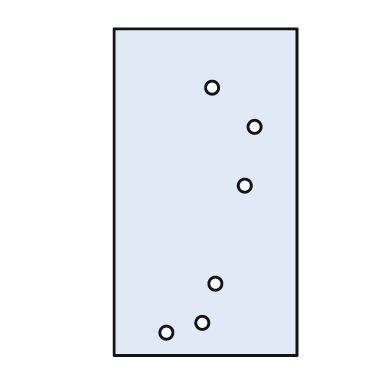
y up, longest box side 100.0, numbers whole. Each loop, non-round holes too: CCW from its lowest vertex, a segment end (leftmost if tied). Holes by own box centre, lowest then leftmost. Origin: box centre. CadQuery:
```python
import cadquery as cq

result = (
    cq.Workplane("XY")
    .moveTo(-28.0, -50.0)
    .lineTo(28.0, -50.0)
    .lineTo(28.0, 50.0)
    .lineTo(-28.0, 50.0)
    .close()
    .moveTo(-12.0, -43.0)
    .circle(2.0)
    .moveTo(-1.0, -40.0)
    .circle(2.0)
    .moveTo(3.0, -28.0)
    .circle(2.0)
    .moveTo(12.0, 2.0)
    .circle(2.0)
    .moveTo(15.0, 20.0)
    .circle(2.0)
    .moveTo(2.0, 32.0)
    .circle(2.0)
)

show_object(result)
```